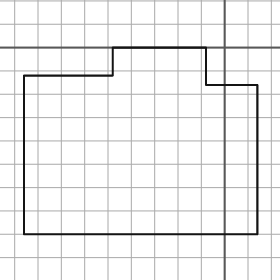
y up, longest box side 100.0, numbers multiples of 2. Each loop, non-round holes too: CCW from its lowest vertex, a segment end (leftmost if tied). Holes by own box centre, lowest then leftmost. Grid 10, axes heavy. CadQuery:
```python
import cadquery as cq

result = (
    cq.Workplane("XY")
    .moveTo(-86.0, -80.0)
    .lineTo(14.0, -80.0)
    .lineTo(14.0, -16.0)
    .lineTo(-8.0, -16.0)
    .lineTo(-8.0, 0.0)
    .lineTo(-48.0, 0.0)
    .lineTo(-48.0, -12.0)
    .lineTo(-86.0, -12.0)
    .close()
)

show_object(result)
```